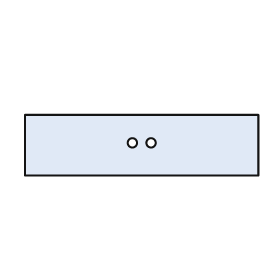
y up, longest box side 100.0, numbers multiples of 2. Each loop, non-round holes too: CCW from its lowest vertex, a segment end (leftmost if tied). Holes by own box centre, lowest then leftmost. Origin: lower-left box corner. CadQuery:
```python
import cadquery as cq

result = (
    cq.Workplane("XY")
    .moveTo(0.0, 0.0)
    .lineTo(100.0, 0.0)
    .lineTo(100.0, 26.0)
    .lineTo(0.0, 26.0)
    .close()
    .moveTo(46.0, 14.0)
    .circle(2.0)
    .moveTo(54.0, 14.0)
    .circle(2.0)
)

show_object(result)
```